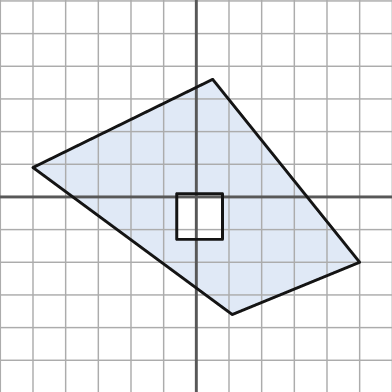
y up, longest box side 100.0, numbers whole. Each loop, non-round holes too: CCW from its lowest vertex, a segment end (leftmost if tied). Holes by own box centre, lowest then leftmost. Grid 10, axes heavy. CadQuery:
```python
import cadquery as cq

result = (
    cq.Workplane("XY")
    .moveTo(11.0, -36.0)
    .lineTo(50.0, -20.0)
    .lineTo(5.0, 36.0)
    .lineTo(-50.0, 9.0)
    .close()
    .moveTo(-6.0, -13.0)
    .lineTo(8.0, -13.0)
    .lineTo(8.0, 1.0)
    .lineTo(-6.0, 1.0)
    .close()
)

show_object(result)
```